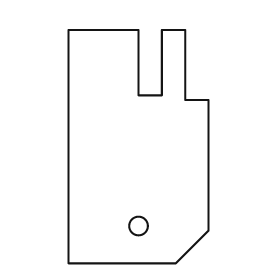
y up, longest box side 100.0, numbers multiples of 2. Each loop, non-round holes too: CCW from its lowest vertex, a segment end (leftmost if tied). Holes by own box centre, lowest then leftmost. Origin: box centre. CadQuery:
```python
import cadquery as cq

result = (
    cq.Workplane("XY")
    .moveTo(-30.0, -50.0)
    .lineTo(16.0, -50.0)
    .lineTo(30.0, -36.0)
    .lineTo(30.0, 20.0)
    .lineTo(20.0, 20.0)
    .lineTo(20.0, 50.0)
    .lineTo(10.0, 50.0)
    .lineTo(10.0, 22.0)
    .lineTo(0.0, 22.0)
    .lineTo(0.0, 50.0)
    .lineTo(-30.0, 50.0)
    .close()
    .moveTo(0.0, -34.0)
    .circle(4.0)
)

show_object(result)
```